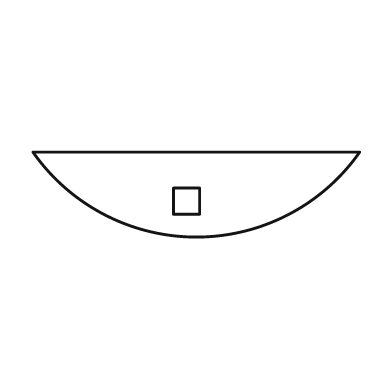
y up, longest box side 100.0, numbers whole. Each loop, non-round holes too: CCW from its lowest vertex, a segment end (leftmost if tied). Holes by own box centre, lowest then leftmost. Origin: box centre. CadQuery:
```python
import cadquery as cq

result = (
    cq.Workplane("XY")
    .moveTo(-50.0, 13.0)
    .threePointArc((0.0, -13.0), (50.0, 13.0))
    .close()
    .moveTo(-7.0, -6.0)
    .lineTo(1.0, -6.0)
    .lineTo(1.0, 2.0)
    .lineTo(-7.0, 2.0)
    .close()
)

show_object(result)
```